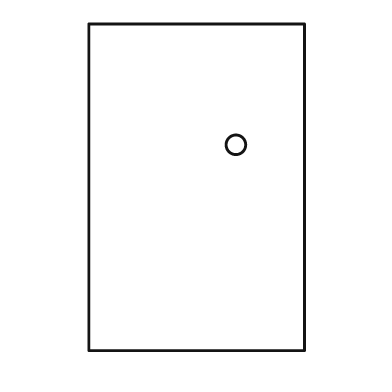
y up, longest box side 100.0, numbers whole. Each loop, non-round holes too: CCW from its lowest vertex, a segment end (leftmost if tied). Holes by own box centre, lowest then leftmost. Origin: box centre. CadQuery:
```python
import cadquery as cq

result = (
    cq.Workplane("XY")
    .moveTo(-33.0, -50.0)
    .lineTo(33.0, -50.0)
    .lineTo(33.0, 50.0)
    .lineTo(-33.0, 50.0)
    .close()
    .moveTo(12.0, 13.0)
    .circle(3.0)
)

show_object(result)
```